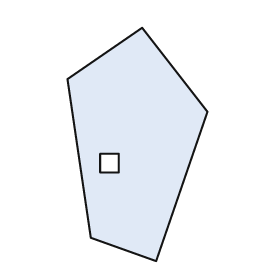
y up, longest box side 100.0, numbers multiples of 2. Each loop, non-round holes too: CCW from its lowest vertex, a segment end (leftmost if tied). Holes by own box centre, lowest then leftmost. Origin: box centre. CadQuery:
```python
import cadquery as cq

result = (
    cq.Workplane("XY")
    .moveTo(8.0, -50.0)
    .lineTo(30.0, 14.0)
    .lineTo(2.0, 50.0)
    .lineTo(-30.0, 28.0)
    .lineTo(-20.0, -40.0)
    .close()
    .moveTo(-16.0, -12.0)
    .lineTo(-8.0, -12.0)
    .lineTo(-8.0, -4.0)
    .lineTo(-16.0, -4.0)
    .close()
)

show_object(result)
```